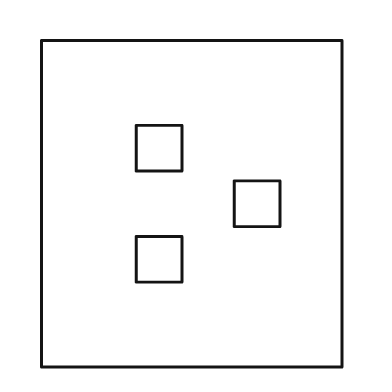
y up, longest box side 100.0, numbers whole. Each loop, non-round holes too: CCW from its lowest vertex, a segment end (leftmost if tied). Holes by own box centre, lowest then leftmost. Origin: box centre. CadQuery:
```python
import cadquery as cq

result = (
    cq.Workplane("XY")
    .moveTo(-46.0, -50.0)
    .lineTo(46.0, -50.0)
    .lineTo(46.0, 50.0)
    .lineTo(-46.0, 50.0)
    .close()
    .moveTo(-17.0, -24.0)
    .lineTo(-3.0, -24.0)
    .lineTo(-3.0, -10.0)
    .lineTo(-17.0, -10.0)
    .close()
    .moveTo(13.0, -7.0)
    .lineTo(27.0, -7.0)
    .lineTo(27.0, 7.0)
    .lineTo(13.0, 7.0)
    .close()
    .moveTo(-17.0, 10.0)
    .lineTo(-3.0, 10.0)
    .lineTo(-3.0, 24.0)
    .lineTo(-17.0, 24.0)
    .close()
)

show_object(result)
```